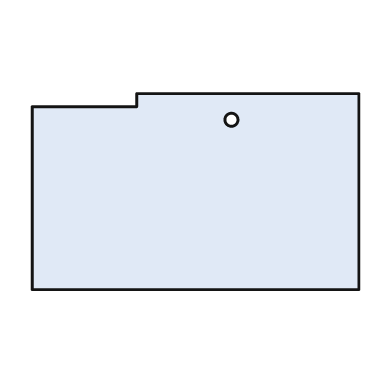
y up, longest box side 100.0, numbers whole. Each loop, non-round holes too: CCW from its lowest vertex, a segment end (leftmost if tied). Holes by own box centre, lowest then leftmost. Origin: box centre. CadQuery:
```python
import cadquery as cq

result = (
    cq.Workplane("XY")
    .moveTo(-50.0, -30.0)
    .lineTo(50.0, -30.0)
    .lineTo(50.0, 30.0)
    .lineTo(-18.0, 30.0)
    .lineTo(-18.0, 26.0)
    .lineTo(-50.0, 26.0)
    .close()
    .moveTo(11.0, 22.0)
    .circle(2.0)
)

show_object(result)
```